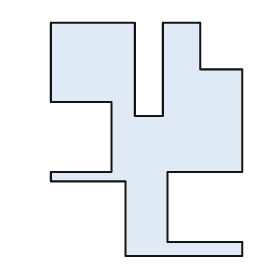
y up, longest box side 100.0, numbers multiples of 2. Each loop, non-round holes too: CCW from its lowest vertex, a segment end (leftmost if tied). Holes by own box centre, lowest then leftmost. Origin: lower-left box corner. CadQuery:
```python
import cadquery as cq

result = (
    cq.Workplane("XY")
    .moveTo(32.0, 0.0)
    .lineTo(82.0, 0.0)
    .lineTo(82.0, 6.0)
    .lineTo(50.0, 6.0)
    .lineTo(50.0, 36.0)
    .lineTo(82.0, 36.0)
    .lineTo(82.0, 80.0)
    .lineTo(64.0, 80.0)
    .lineTo(64.0, 100.0)
    .lineTo(48.0, 100.0)
    .lineTo(48.0, 60.0)
    .lineTo(36.0, 60.0)
    .lineTo(36.0, 100.0)
    .lineTo(0.0, 100.0)
    .lineTo(0.0, 66.0)
    .lineTo(26.0, 66.0)
    .lineTo(26.0, 36.0)
    .lineTo(0.0, 36.0)
    .lineTo(0.0, 32.0)
    .lineTo(32.0, 32.0)
    .close()
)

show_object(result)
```